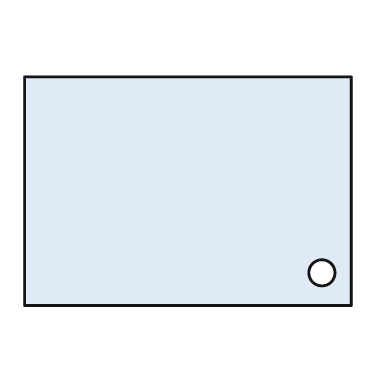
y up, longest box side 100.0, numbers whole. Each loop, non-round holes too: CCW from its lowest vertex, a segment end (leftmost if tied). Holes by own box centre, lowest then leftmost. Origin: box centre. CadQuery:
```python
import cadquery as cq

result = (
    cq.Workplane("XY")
    .moveTo(-50.0, -35.0)
    .lineTo(50.0, -35.0)
    .lineTo(50.0, 35.0)
    .lineTo(-50.0, 35.0)
    .close()
    .moveTo(41.0, -25.0)
    .circle(4.0)
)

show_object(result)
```